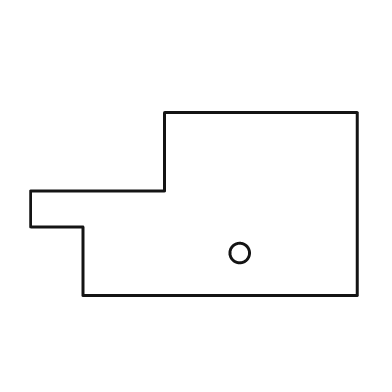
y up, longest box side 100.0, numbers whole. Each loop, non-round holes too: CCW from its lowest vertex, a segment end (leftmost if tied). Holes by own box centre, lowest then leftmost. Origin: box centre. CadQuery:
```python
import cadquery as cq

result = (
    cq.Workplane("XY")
    .moveTo(-34.0, -28.0)
    .lineTo(50.0, -28.0)
    .lineTo(50.0, 28.0)
    .lineTo(-9.0, 28.0)
    .lineTo(-9.0, 4.0)
    .lineTo(-50.0, 4.0)
    .lineTo(-50.0, -7.0)
    .lineTo(-34.0, -7.0)
    .close()
    .moveTo(14.0, -15.0)
    .circle(3.0)
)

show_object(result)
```